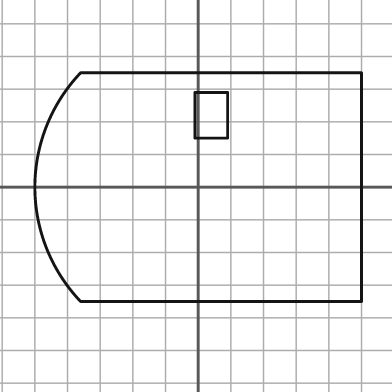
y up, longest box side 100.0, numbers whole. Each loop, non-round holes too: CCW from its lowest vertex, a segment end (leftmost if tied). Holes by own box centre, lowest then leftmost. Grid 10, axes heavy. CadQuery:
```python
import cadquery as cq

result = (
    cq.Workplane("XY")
    .moveTo(-36.0, -35.0)
    .lineTo(50.0, -35.0)
    .lineTo(50.0, 35.0)
    .lineTo(-36.0, 35.0)
    .threePointArc((-50.0, 0.0), (-36.0, -35.0))
    .close()
    .moveTo(-1.0, 15.0)
    .lineTo(9.0, 15.0)
    .lineTo(9.0, 29.0)
    .lineTo(-1.0, 29.0)
    .close()
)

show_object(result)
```